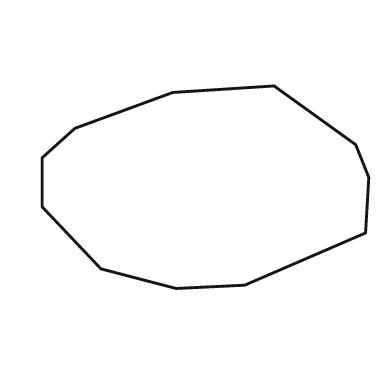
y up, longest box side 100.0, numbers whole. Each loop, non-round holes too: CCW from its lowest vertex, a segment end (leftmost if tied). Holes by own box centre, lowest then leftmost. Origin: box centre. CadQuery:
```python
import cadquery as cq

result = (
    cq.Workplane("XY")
    .moveTo(-9.0, -31.0)
    .lineTo(12.0, -30.0)
    .lineTo(49.0, -14.0)
    .lineTo(50.0, 3.0)
    .lineTo(46.0, 13.0)
    .lineTo(21.0, 31.0)
    .lineTo(-10.0, 29.0)
    .lineTo(-40.0, 18.0)
    .lineTo(-50.0, 9.0)
    .lineTo(-50.0, -6.0)
    .lineTo(-32.0, -25.0)
    .close()
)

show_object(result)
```